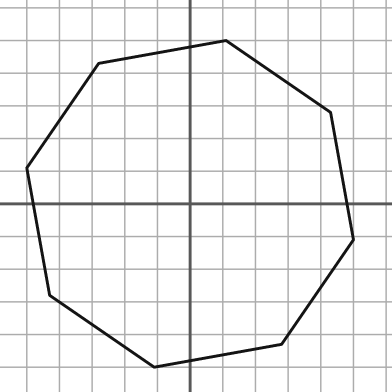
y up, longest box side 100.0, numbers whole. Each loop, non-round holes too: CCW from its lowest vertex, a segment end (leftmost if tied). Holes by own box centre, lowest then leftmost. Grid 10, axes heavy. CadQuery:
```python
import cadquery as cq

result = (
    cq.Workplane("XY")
    .moveTo(-11.0, -50.0)
    .lineTo(28.0, -43.0)
    .lineTo(50.0, -11.0)
    .lineTo(43.0, 28.0)
    .lineTo(11.0, 50.0)
    .lineTo(-28.0, 43.0)
    .lineTo(-50.0, 11.0)
    .lineTo(-43.0, -28.0)
    .close()
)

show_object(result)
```